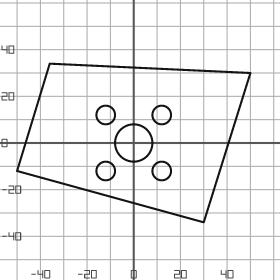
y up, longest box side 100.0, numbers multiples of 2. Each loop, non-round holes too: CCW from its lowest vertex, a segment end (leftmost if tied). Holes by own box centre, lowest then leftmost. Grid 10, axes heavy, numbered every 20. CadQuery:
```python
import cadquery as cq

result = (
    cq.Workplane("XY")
    .moveTo(30.0, -34.0)
    .lineTo(50.0, 30.0)
    .lineTo(-36.0, 34.0)
    .lineTo(-50.0, -12.0)
    .close()
    .moveTo(-12.0, -12.0)
    .circle(4.0)
    .moveTo(12.0, -12.0)
    .circle(4.0)
    .moveTo(0.0, 0.0)
    .circle(8.0)
    .moveTo(-12.0, 12.0)
    .circle(4.0)
    .moveTo(12.0, 12.0)
    .circle(4.0)
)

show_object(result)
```